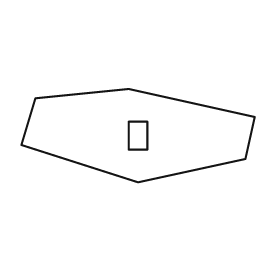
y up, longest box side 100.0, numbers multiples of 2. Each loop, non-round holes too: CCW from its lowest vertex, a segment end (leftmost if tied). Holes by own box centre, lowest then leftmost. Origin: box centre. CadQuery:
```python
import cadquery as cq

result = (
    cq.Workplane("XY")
    .moveTo(0.0, -20.0)
    .lineTo(46.0, -10.0)
    .lineTo(50.0, 8.0)
    .lineTo(-4.0, 20.0)
    .lineTo(-44.0, 16.0)
    .lineTo(-50.0, -4.0)
    .close()
    .moveTo(-4.0, -6.0)
    .lineTo(4.0, -6.0)
    .lineTo(4.0, 6.0)
    .lineTo(-4.0, 6.0)
    .close()
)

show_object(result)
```